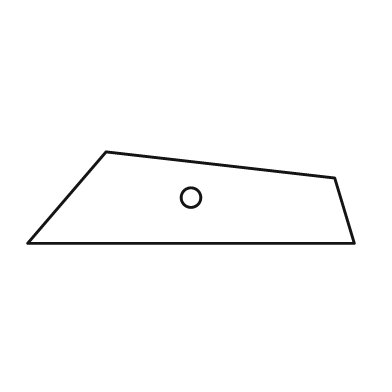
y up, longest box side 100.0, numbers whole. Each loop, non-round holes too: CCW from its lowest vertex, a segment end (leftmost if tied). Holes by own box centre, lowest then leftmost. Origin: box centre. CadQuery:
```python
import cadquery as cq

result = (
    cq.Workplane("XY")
    .moveTo(-50.0, -14.0)
    .lineTo(50.0, -14.0)
    .lineTo(44.0, 6.0)
    .lineTo(-26.0, 14.0)
    .close()
    .moveTo(0.0, 0.0)
    .circle(3.0)
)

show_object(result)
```